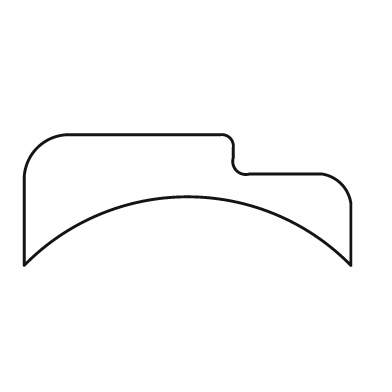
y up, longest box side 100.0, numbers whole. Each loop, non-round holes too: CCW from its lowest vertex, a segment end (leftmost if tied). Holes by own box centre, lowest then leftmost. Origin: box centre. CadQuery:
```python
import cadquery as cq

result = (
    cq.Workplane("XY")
    .moveTo(-50.0, -20.0)
    .threePointArc((0.0, 1.0), (50.0, -20.0))
    .lineTo(50.0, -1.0)
    .threePointArc((47.0, 5.0), (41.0, 8.0))
    .lineTo(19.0, 8.0)
    .threePointArc((15.0, 9.0), (14.0, 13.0))
    .lineTo(14.0, 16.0)
    .threePointArc((13.0, 19.0), (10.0, 20.0))
    .lineTo(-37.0, 20.0)
    .threePointArc((-46.0, 16.0), (-50.0, 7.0))
    .close()
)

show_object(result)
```